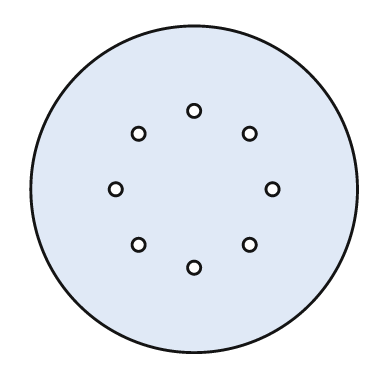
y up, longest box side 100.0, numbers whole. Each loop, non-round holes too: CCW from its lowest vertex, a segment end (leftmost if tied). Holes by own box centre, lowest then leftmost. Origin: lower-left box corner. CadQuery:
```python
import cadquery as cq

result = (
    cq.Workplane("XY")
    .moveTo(50.0, 50.0)
    .circle(50.0)
    .moveTo(50.0, 26.0)
    .circle(2.0)
    .moveTo(33.0, 33.0)
    .circle(2.0)
    .moveTo(67.0, 33.0)
    .circle(2.0)
    .moveTo(26.0, 50.0)
    .circle(2.0)
    .moveTo(74.0, 50.0)
    .circle(2.0)
    .moveTo(33.0, 67.0)
    .circle(2.0)
    .moveTo(67.0, 67.0)
    .circle(2.0)
    .moveTo(50.0, 74.0)
    .circle(2.0)
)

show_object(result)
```